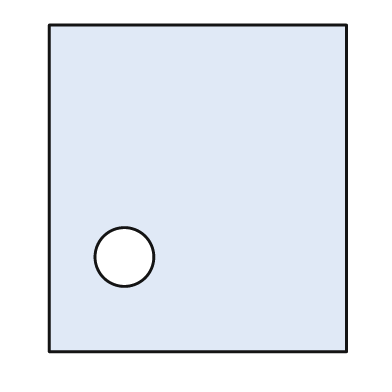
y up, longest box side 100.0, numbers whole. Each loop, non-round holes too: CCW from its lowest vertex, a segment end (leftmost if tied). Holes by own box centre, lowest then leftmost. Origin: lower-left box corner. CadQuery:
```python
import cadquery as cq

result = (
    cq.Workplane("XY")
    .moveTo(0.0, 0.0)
    .lineTo(91.0, 0.0)
    .lineTo(91.0, 100.0)
    .lineTo(0.0, 100.0)
    .close()
    .moveTo(23.0, 29.0)
    .circle(9.0)
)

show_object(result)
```